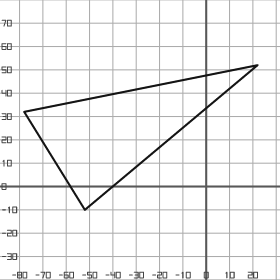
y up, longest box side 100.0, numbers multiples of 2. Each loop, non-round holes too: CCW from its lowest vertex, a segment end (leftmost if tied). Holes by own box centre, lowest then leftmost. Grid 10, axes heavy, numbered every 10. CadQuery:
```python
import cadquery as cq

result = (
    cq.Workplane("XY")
    .moveTo(-52.0, -10.0)
    .lineTo(22.0, 52.0)
    .lineTo(-78.0, 32.0)
    .close()
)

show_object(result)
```